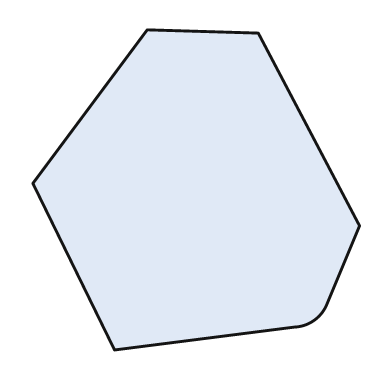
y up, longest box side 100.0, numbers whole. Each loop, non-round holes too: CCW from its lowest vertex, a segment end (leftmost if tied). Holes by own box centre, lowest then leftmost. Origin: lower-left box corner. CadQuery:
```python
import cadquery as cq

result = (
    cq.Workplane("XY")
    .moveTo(25.0, 0.0)
    .lineTo(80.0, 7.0)
    .threePointArc((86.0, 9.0), (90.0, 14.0))
    .lineTo(100.0, 38.0)
    .lineTo(69.0, 97.0)
    .lineTo(35.0, 98.0)
    .lineTo(0.0, 51.0)
    .close()
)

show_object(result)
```